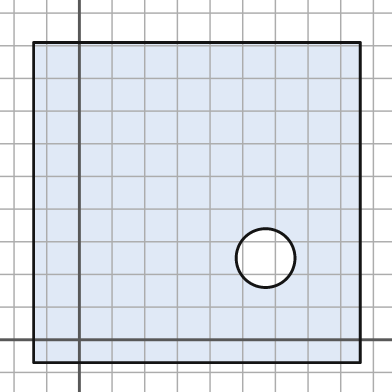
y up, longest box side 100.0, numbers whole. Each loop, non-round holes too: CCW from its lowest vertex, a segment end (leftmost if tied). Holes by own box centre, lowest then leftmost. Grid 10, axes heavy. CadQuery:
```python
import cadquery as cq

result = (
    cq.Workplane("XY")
    .moveTo(-14.0, -7.0)
    .lineTo(86.0, -7.0)
    .lineTo(86.0, 91.0)
    .lineTo(-14.0, 91.0)
    .close()
    .moveTo(57.0, 25.0)
    .circle(9.0)
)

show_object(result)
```